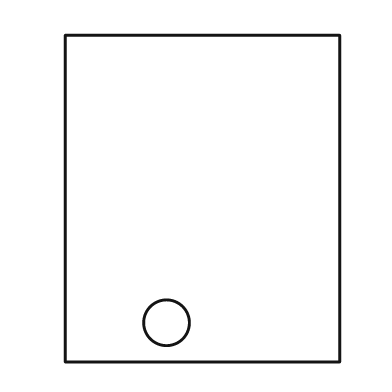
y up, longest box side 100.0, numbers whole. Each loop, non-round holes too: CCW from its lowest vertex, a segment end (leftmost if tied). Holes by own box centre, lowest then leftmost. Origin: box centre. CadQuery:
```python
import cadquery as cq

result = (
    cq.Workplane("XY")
    .moveTo(-42.0, -50.0)
    .lineTo(42.0, -50.0)
    .lineTo(42.0, 50.0)
    .lineTo(-42.0, 50.0)
    .close()
    .moveTo(-11.0, -38.0)
    .circle(7.0)
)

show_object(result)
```